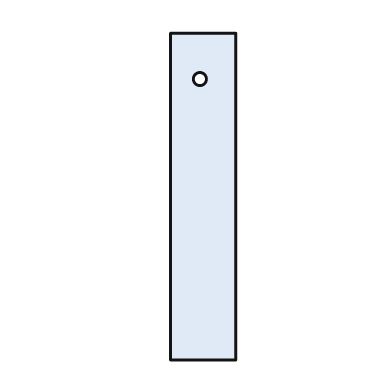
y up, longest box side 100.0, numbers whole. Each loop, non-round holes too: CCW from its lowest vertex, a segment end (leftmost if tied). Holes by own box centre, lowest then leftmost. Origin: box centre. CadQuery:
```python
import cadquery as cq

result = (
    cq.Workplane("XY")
    .moveTo(-10.0, -50.0)
    .lineTo(10.0, -50.0)
    .lineTo(10.0, 50.0)
    .lineTo(-10.0, 50.0)
    .close()
    .moveTo(-1.0, 36.0)
    .circle(2.0)
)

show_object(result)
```